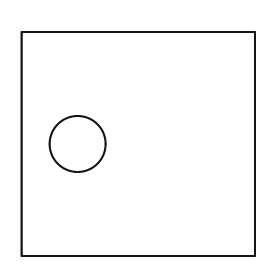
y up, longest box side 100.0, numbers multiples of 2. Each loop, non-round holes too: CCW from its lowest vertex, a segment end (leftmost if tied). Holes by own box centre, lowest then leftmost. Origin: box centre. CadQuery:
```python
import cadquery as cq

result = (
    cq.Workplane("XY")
    .moveTo(-50.0, -48.0)
    .lineTo(50.0, -48.0)
    .lineTo(50.0, 48.0)
    .lineTo(-50.0, 48.0)
    .close()
    .moveTo(-26.0, 0.0)
    .circle(12.0)
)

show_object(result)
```